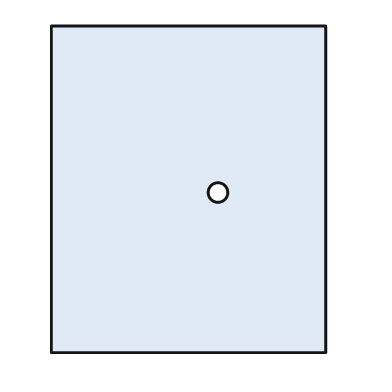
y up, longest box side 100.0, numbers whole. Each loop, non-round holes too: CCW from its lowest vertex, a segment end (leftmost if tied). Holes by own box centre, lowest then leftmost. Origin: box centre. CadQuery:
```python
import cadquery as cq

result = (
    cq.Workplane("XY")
    .moveTo(-42.0, -50.0)
    .lineTo(42.0, -50.0)
    .lineTo(42.0, 50.0)
    .lineTo(-42.0, 50.0)
    .close()
    .moveTo(9.0, -1.0)
    .circle(3.0)
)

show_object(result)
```